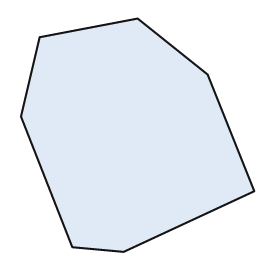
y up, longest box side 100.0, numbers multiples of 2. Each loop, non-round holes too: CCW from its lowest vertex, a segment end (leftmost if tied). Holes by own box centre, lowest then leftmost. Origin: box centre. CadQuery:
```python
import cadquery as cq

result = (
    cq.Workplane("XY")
    .moveTo(-6.0, -50.0)
    .lineTo(50.0, -24.0)
    .lineTo(30.0, 26.0)
    .lineTo(0.0, 50.0)
    .lineTo(-42.0, 42.0)
    .lineTo(-50.0, 8.0)
    .lineTo(-28.0, -48.0)
    .close()
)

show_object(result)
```